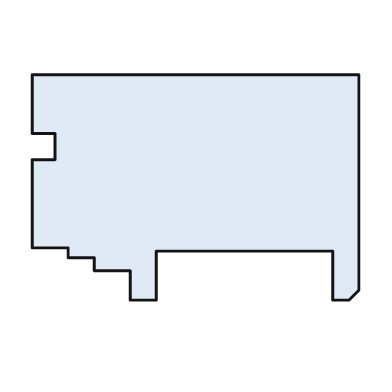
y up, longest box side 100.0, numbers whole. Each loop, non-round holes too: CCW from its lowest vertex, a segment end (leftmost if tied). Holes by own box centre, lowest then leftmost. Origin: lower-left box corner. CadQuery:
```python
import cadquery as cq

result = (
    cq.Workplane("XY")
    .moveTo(30.0, 0.0)
    .lineTo(38.0, 0.0)
    .lineTo(38.0, 15.0)
    .lineTo(92.0, 15.0)
    .lineTo(92.0, 0.0)
    .lineTo(97.0, 0.0)
    .lineTo(100.0, 3.0)
    .lineTo(100.0, 69.0)
    .lineTo(0.0, 69.0)
    .lineTo(0.0, 51.0)
    .lineTo(7.0, 51.0)
    .lineTo(7.0, 43.0)
    .lineTo(0.0, 43.0)
    .lineTo(0.0, 16.0)
    .lineTo(11.0, 16.0)
    .lineTo(11.0, 13.0)
    .lineTo(19.0, 13.0)
    .lineTo(19.0, 9.0)
    .lineTo(30.0, 9.0)
    .close()
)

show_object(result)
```